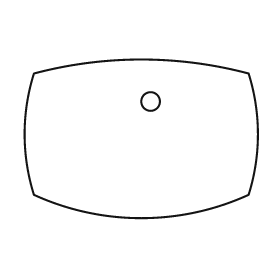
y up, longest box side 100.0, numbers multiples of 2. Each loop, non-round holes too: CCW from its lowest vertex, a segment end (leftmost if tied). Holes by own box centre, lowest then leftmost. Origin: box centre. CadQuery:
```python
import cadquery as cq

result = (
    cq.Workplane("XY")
    .moveTo(-46.0, -24.0)
    .threePointArc((0.0, -34.0), (46.0, -24.0))
    .threePointArc((50.0, 2.0), (46.0, 28.0))
    .threePointArc((0.0, 34.0), (-46.0, 28.0))
    .threePointArc((-50.0, 2.0), (-46.0, -24.0))
    .close()
    .moveTo(4.0, 16.0)
    .circle(4.0)
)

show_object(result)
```